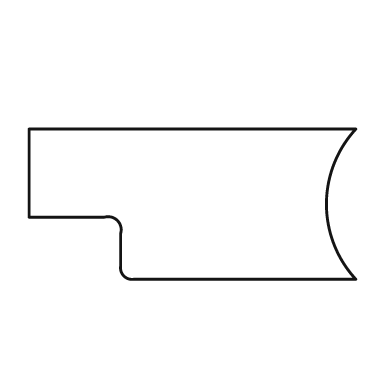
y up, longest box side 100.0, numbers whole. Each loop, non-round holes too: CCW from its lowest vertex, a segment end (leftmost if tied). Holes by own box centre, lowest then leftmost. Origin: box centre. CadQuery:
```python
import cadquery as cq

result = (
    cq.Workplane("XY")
    .moveTo(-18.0, -23.0)
    .lineTo(50.0, -23.0)
    .threePointArc((41.0, 0.0), (50.0, 23.0))
    .lineTo(-50.0, 23.0)
    .lineTo(-50.0, -4.0)
    .lineTo(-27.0, -4.0)
    .threePointArc((-23.0, -5.0), (-22.0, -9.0))
    .lineTo(-22.0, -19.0)
    .threePointArc((-21.0, -22.0), (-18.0, -23.0))
    .close()
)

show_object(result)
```